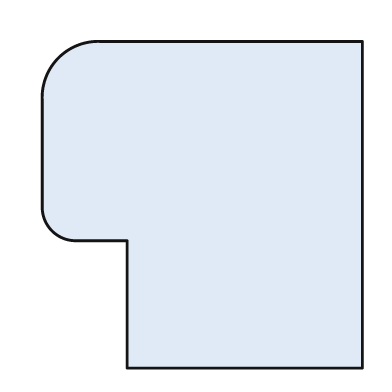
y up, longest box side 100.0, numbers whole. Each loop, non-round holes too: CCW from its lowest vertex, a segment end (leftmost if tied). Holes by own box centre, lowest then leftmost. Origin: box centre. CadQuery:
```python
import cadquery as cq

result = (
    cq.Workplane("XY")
    .moveTo(-23.0, -50.0)
    .lineTo(49.0, -50.0)
    .lineTo(49.0, 50.0)
    .lineTo(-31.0, 50.0)
    .threePointArc((-44.0, 45.0), (-49.0, 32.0))
    .lineTo(-49.0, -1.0)
    .threePointArc((-46.0, -8.0), (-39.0, -11.0))
    .lineTo(-23.0, -11.0)
    .close()
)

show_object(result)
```